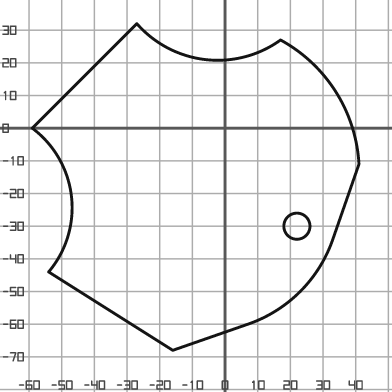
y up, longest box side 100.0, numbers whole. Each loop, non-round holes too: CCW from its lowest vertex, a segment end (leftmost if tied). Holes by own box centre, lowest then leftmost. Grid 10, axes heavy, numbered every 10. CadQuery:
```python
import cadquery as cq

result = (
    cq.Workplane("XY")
    .moveTo(-16.0, -68.0)
    .lineTo(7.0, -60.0)
    .threePointArc((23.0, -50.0), (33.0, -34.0))
    .lineTo(41.0, -11.0)
    .threePointArc((34.0, 11.0), (17.0, 27.0))
    .threePointArc((-6.0, 21.0), (-27.0, 32.0))
    .lineTo(-59.0, 0.0)
    .threePointArc((-47.0, -21.0), (-54.0, -44.0))
    .close()
    .moveTo(22.0, -30.0)
    .circle(4.0)
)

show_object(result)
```